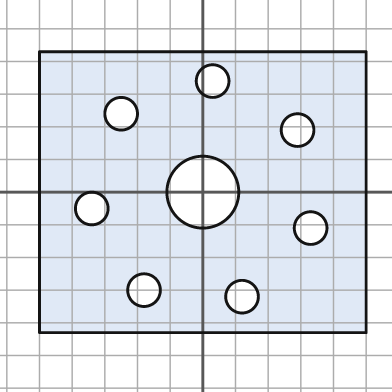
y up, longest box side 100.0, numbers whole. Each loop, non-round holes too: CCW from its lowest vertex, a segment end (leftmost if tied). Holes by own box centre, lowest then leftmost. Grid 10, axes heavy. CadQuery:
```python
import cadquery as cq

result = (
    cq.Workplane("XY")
    .moveTo(-50.0, -43.0)
    .lineTo(50.0, -43.0)
    .lineTo(50.0, 43.0)
    .lineTo(-50.0, 43.0)
    .close()
    .moveTo(12.0, -32.0)
    .circle(5.0)
    .moveTo(-18.0, -30.0)
    .circle(5.0)
    .moveTo(33.0, -11.0)
    .circle(5.0)
    .moveTo(-34.0, -5.0)
    .circle(5.0)
    .moveTo(0.0, 0.0)
    .circle(11.0)
    .moveTo(29.0, 19.0)
    .circle(5.0)
    .moveTo(-25.0, 24.0)
    .circle(5.0)
    .moveTo(3.0, 34.0)
    .circle(5.0)
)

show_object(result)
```